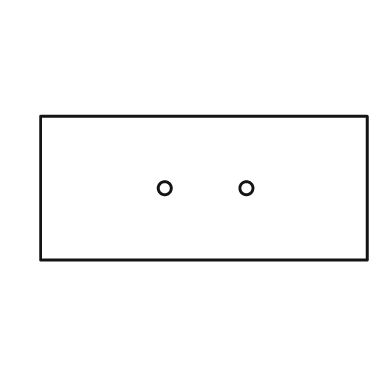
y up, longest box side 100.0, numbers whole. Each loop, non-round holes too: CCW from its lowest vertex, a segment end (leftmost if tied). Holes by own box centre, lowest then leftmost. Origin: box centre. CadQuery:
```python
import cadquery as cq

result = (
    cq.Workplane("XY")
    .moveTo(-50.0, -22.0)
    .lineTo(50.0, -22.0)
    .lineTo(50.0, 22.0)
    .lineTo(-50.0, 22.0)
    .close()
    .moveTo(-12.0, 0.0)
    .circle(2.0)
    .moveTo(13.0, 0.0)
    .circle(2.0)
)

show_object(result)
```